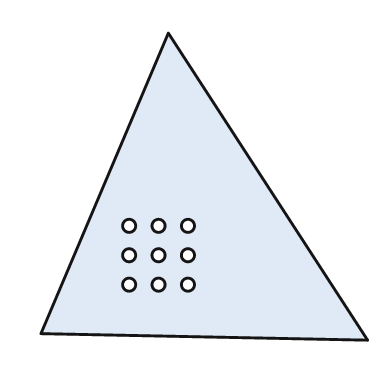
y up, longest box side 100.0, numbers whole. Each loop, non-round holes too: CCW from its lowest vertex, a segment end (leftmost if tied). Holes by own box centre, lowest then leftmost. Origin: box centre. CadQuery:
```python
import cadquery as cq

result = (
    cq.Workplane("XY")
    .moveTo(50.0, -47.0)
    .lineTo(-11.0, 47.0)
    .lineTo(-50.0, -45.0)
    .close()
    .moveTo(-23.0, -30.0)
    .circle(2.0)
    .moveTo(-14.0, -30.0)
    .circle(2.0)
    .moveTo(-5.0, -30.0)
    .circle(2.0)
    .moveTo(-23.0, -21.0)
    .circle(2.0)
    .moveTo(-14.0, -21.0)
    .circle(2.0)
    .moveTo(-5.0, -21.0)
    .circle(2.0)
    .moveTo(-23.0, -12.0)
    .circle(2.0)
    .moveTo(-14.0, -12.0)
    .circle(2.0)
    .moveTo(-5.0, -12.0)
    .circle(2.0)
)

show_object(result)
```